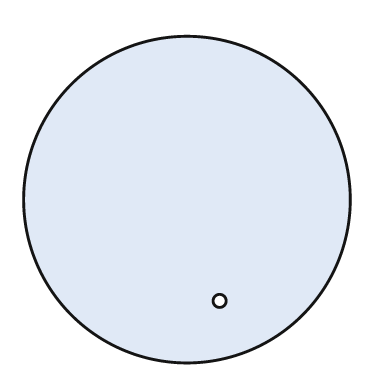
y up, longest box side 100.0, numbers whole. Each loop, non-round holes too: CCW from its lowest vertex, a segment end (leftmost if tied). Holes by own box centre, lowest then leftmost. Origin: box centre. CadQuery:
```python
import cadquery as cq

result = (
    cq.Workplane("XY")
    .moveTo(0.0, 0.0)
    .circle(50.0)
    .moveTo(10.0, -31.0)
    .circle(2.0)
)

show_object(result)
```